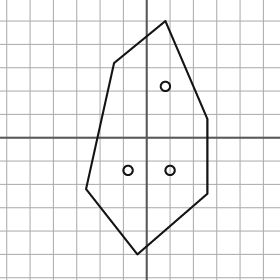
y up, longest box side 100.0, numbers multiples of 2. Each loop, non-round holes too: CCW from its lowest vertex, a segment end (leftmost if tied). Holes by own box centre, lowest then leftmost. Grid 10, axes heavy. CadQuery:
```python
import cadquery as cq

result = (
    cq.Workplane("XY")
    .moveTo(-4.0, -50.0)
    .lineTo(26.0, -24.0)
    .lineTo(26.0, 8.0)
    .lineTo(8.0, 50.0)
    .lineTo(-14.0, 32.0)
    .lineTo(-26.0, -22.0)
    .close()
    .moveTo(-8.0, -14.0)
    .circle(2.0)
    .moveTo(10.0, -14.0)
    .circle(2.0)
    .moveTo(8.0, 22.0)
    .circle(2.0)
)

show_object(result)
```